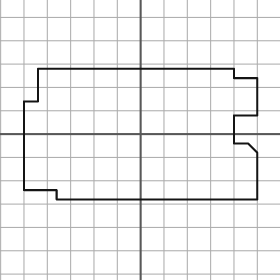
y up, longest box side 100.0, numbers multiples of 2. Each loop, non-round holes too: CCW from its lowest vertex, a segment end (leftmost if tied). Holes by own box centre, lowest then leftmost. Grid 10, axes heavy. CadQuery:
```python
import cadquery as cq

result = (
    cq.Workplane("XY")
    .moveTo(-36.0, -28.0)
    .lineTo(50.0, -28.0)
    .lineTo(50.0, -8.0)
    .lineTo(46.0, -4.0)
    .lineTo(40.0, -4.0)
    .lineTo(40.0, 8.0)
    .lineTo(50.0, 8.0)
    .lineTo(50.0, 24.0)
    .lineTo(40.0, 24.0)
    .lineTo(40.0, 28.0)
    .lineTo(-44.0, 28.0)
    .lineTo(-44.0, 14.0)
    .lineTo(-50.0, 14.0)
    .lineTo(-50.0, -24.0)
    .lineTo(-36.0, -24.0)
    .close()
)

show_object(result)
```